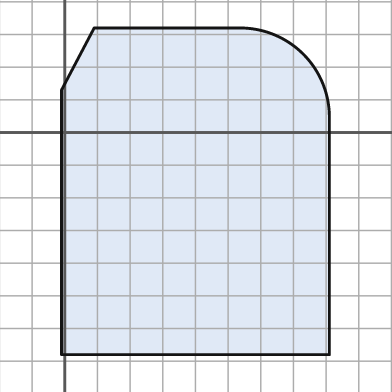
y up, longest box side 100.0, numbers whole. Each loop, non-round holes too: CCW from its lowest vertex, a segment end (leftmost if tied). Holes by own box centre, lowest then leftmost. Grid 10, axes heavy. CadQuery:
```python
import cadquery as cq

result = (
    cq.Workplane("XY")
    .moveTo(-1.0, -68.0)
    .lineTo(81.0, -68.0)
    .lineTo(81.0, 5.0)
    .threePointArc((73.0, 24.0), (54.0, 32.0))
    .lineTo(9.0, 32.0)
    .lineTo(-1.0, 13.0)
    .close()
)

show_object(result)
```